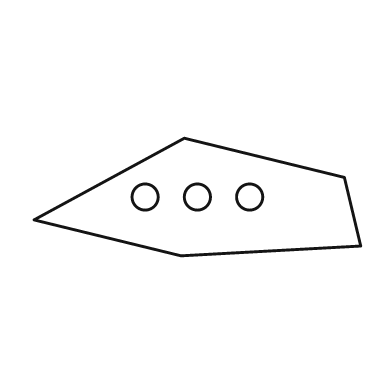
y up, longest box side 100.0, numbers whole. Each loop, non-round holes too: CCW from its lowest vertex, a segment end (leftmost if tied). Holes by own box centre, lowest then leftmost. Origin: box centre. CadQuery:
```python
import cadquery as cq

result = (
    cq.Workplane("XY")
    .moveTo(-5.0, -18.0)
    .lineTo(50.0, -15.0)
    .lineTo(45.0, 6.0)
    .lineTo(-4.0, 18.0)
    .lineTo(-50.0, -7.0)
    .close()
    .moveTo(-16.0, 0.0)
    .circle(4.0)
    .moveTo(0.0, 0.0)
    .circle(4.0)
    .moveTo(16.0, 0.0)
    .circle(4.0)
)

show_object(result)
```